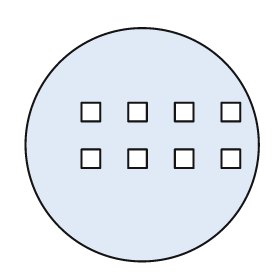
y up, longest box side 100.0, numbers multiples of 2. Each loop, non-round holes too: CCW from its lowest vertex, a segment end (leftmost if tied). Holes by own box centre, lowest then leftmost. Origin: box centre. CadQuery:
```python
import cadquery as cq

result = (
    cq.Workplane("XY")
    .moveTo(0.0, 0.0)
    .circle(50.0)
    .moveTo(-26.0, -10.0)
    .lineTo(-18.0, -10.0)
    .lineTo(-18.0, -2.0)
    .lineTo(-26.0, -2.0)
    .close()
    .moveTo(-6.0, -10.0)
    .lineTo(2.0, -10.0)
    .lineTo(2.0, -2.0)
    .lineTo(-6.0, -2.0)
    .close()
    .moveTo(14.0, -10.0)
    .lineTo(22.0, -10.0)
    .lineTo(22.0, -2.0)
    .lineTo(14.0, -2.0)
    .close()
    .moveTo(34.0, -10.0)
    .lineTo(42.0, -10.0)
    .lineTo(42.0, -2.0)
    .lineTo(34.0, -2.0)
    .close()
    .moveTo(-26.0, 10.0)
    .lineTo(-18.0, 10.0)
    .lineTo(-18.0, 18.0)
    .lineTo(-26.0, 18.0)
    .close()
    .moveTo(-6.0, 10.0)
    .lineTo(2.0, 10.0)
    .lineTo(2.0, 18.0)
    .lineTo(-6.0, 18.0)
    .close()
    .moveTo(14.0, 10.0)
    .lineTo(22.0, 10.0)
    .lineTo(22.0, 18.0)
    .lineTo(14.0, 18.0)
    .close()
    .moveTo(34.0, 10.0)
    .lineTo(42.0, 10.0)
    .lineTo(42.0, 18.0)
    .lineTo(34.0, 18.0)
    .close()
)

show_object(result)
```